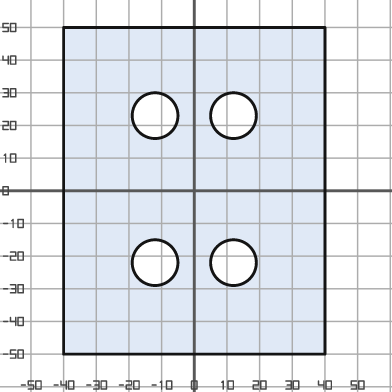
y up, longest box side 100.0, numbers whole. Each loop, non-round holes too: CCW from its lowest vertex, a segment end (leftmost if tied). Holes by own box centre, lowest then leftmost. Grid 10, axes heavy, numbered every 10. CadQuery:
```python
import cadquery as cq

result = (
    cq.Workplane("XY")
    .moveTo(-40.0, -50.0)
    .lineTo(40.0, -50.0)
    .lineTo(40.0, 50.0)
    .lineTo(-40.0, 50.0)
    .close()
    .moveTo(-12.0, -22.0)
    .circle(7.0)
    .moveTo(12.0, -22.0)
    .circle(7.0)
    .moveTo(-12.0, 23.0)
    .circle(7.0)
    .moveTo(12.0, 23.0)
    .circle(7.0)
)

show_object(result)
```